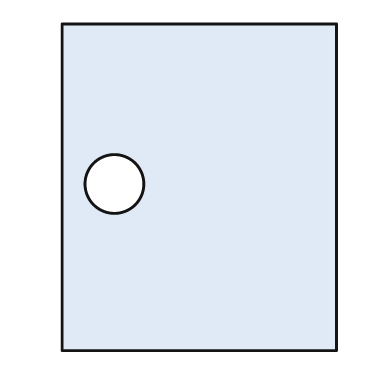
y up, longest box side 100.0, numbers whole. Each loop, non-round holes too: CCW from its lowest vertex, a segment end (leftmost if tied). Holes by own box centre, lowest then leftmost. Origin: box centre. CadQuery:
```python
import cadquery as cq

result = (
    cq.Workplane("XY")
    .moveTo(-42.0, -50.0)
    .lineTo(42.0, -50.0)
    .lineTo(42.0, 50.0)
    .lineTo(-42.0, 50.0)
    .close()
    .moveTo(-26.0, 1.0)
    .circle(9.0)
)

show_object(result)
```